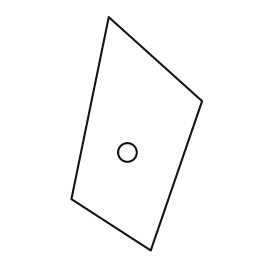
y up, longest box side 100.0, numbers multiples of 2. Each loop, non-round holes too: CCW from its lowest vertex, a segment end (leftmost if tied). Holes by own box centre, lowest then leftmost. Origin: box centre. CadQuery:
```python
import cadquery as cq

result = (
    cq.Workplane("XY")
    .moveTo(6.0, -50.0)
    .lineTo(28.0, 14.0)
    .lineTo(-12.0, 50.0)
    .lineTo(-28.0, -28.0)
    .close()
    .moveTo(-4.0, -8.0)
    .circle(4.0)
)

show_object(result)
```